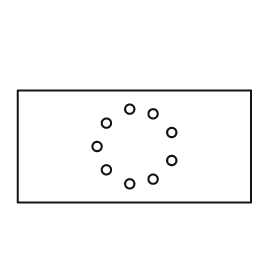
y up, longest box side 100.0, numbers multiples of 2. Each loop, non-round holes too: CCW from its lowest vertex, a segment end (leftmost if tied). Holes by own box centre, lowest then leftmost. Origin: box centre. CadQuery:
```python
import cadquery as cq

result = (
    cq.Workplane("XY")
    .moveTo(-50.0, -24.0)
    .lineTo(50.0, -24.0)
    .lineTo(50.0, 24.0)
    .lineTo(-50.0, 24.0)
    .close()
    .moveTo(-2.0, -16.0)
    .circle(2.0)
    .moveTo(8.0, -14.0)
    .circle(2.0)
    .moveTo(-12.0, -10.0)
    .circle(2.0)
    .moveTo(16.0, -6.0)
    .circle(2.0)
    .moveTo(-16.0, 0.0)
    .circle(2.0)
    .moveTo(16.0, 6.0)
    .circle(2.0)
    .moveTo(-12.0, 10.0)
    .circle(2.0)
    .moveTo(8.0, 14.0)
    .circle(2.0)
    .moveTo(-2.0, 16.0)
    .circle(2.0)
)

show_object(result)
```